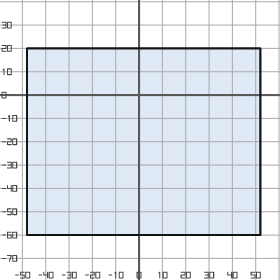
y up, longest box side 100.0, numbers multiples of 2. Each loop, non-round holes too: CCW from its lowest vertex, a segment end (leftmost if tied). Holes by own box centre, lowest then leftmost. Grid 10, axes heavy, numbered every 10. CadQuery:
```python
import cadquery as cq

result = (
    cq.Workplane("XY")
    .moveTo(-48.0, -60.0)
    .lineTo(52.0, -60.0)
    .lineTo(52.0, 20.0)
    .lineTo(-48.0, 20.0)
    .close()
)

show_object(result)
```